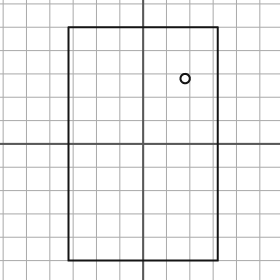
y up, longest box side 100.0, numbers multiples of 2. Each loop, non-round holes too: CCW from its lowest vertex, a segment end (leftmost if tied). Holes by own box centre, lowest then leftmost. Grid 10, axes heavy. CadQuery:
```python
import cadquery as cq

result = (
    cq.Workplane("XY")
    .moveTo(-32.0, -50.0)
    .lineTo(32.0, -50.0)
    .lineTo(32.0, 50.0)
    .lineTo(-32.0, 50.0)
    .close()
    .moveTo(18.0, 28.0)
    .circle(2.0)
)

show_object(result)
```